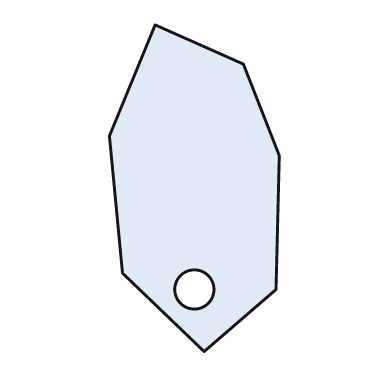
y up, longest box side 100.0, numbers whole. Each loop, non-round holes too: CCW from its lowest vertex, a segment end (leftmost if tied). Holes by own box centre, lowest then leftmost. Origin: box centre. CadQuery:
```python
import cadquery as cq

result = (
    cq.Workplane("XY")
    .moveTo(3.0, -50.0)
    .lineTo(25.0, -31.0)
    .lineTo(26.0, 10.0)
    .lineTo(15.0, 38.0)
    .lineTo(-12.0, 50.0)
    .lineTo(-26.0, 16.0)
    .lineTo(-22.0, -26.0)
    .close()
    .moveTo(0.0, -31.0)
    .circle(6.0)
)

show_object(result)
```